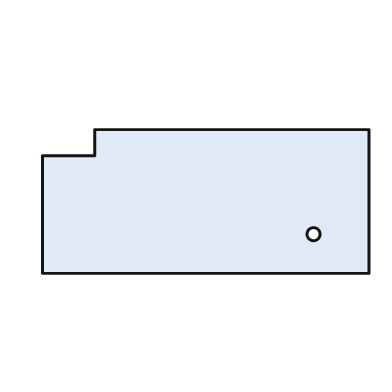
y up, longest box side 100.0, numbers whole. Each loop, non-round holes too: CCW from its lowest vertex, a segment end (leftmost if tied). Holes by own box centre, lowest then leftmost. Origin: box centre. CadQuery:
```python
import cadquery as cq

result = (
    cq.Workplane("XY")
    .moveTo(-50.0, -22.0)
    .lineTo(50.0, -22.0)
    .lineTo(50.0, 22.0)
    .lineTo(-34.0, 22.0)
    .lineTo(-34.0, 14.0)
    .lineTo(-50.0, 14.0)
    .close()
    .moveTo(33.0, -10.0)
    .circle(2.0)
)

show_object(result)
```